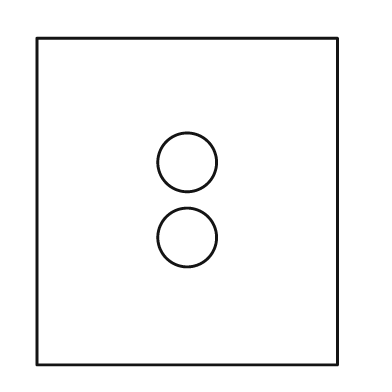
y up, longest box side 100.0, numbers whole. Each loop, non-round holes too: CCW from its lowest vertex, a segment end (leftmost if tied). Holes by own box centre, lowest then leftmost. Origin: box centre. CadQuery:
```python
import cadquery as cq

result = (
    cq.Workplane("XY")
    .moveTo(-46.0, -50.0)
    .lineTo(46.0, -50.0)
    .lineTo(46.0, 50.0)
    .lineTo(-46.0, 50.0)
    .close()
    .moveTo(0.0, -11.0)
    .circle(9.0)
    .moveTo(0.0, 12.0)
    .circle(9.0)
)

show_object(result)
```